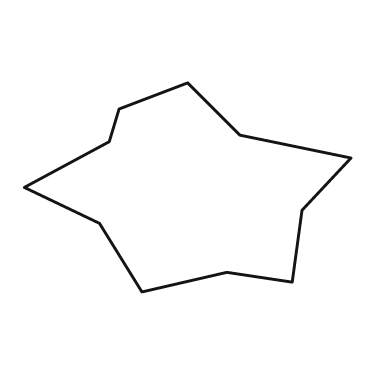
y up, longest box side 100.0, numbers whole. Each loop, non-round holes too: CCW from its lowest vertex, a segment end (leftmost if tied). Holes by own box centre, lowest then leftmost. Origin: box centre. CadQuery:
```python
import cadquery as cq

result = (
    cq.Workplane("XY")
    .moveTo(-14.0, -32.0)
    .lineTo(12.0, -26.0)
    .lineTo(32.0, -29.0)
    .lineTo(35.0, -7.0)
    .lineTo(50.0, 9.0)
    .lineTo(16.0, 16.0)
    .lineTo(0.0, 32.0)
    .lineTo(-21.0, 24.0)
    .lineTo(-24.0, 14.0)
    .lineTo(-50.0, 0.0)
    .lineTo(-27.0, -11.0)
    .close()
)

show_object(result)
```